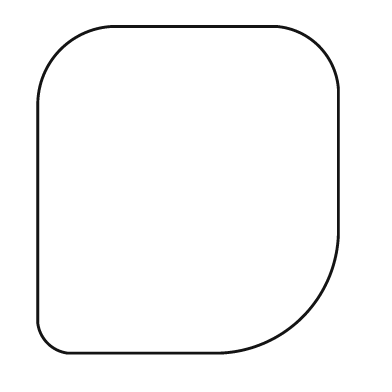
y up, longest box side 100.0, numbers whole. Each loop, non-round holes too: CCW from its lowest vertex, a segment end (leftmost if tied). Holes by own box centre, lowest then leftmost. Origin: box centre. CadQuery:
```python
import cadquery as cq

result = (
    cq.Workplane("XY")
    .moveTo(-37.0, -50.0)
    .lineTo(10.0, -50.0)
    .threePointArc((35.0, -39.0), (46.0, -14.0))
    .lineTo(46.0, 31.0)
    .threePointArc((40.0, 44.0), (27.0, 50.0))
    .lineTo(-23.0, 50.0)
    .threePointArc((-39.0, 43.0), (-46.0, 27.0))
    .lineTo(-46.0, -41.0)
    .threePointArc((-43.0, -47.0), (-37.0, -50.0))
    .close()
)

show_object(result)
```